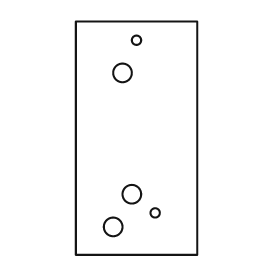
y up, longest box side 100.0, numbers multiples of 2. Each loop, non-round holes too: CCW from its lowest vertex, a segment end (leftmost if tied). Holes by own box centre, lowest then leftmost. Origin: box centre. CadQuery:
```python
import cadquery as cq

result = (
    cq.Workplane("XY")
    .moveTo(-26.0, -50.0)
    .lineTo(26.0, -50.0)
    .lineTo(26.0, 50.0)
    .lineTo(-26.0, 50.0)
    .close()
    .moveTo(-10.0, -38.0)
    .circle(4.0)
    .moveTo(8.0, -32.0)
    .circle(2.0)
    .moveTo(-2.0, -24.0)
    .circle(4.0)
    .moveTo(-6.0, 28.0)
    .circle(4.0)
    .moveTo(0.0, 42.0)
    .circle(2.0)
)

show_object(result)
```